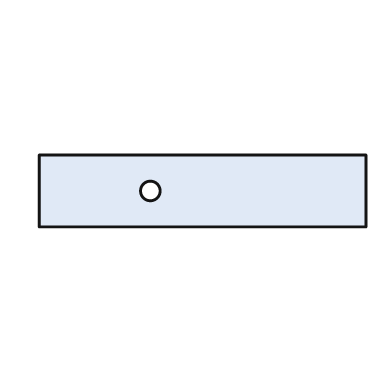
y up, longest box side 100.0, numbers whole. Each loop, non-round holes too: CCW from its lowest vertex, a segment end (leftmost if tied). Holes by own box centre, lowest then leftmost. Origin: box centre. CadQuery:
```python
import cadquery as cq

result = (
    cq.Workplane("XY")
    .moveTo(-50.0, -11.0)
    .lineTo(50.0, -11.0)
    .lineTo(50.0, 11.0)
    .lineTo(-50.0, 11.0)
    .close()
    .moveTo(-16.0, 0.0)
    .circle(3.0)
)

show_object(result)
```